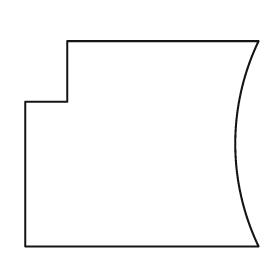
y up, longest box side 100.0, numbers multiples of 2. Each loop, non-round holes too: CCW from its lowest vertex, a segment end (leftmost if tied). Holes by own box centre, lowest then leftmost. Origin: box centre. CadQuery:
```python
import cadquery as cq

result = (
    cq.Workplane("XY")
    .moveTo(-50.0, -44.0)
    .lineTo(50.0, -44.0)
    .threePointArc((40.0, 0.0), (50.0, 44.0))
    .lineTo(-32.0, 44.0)
    .lineTo(-32.0, 18.0)
    .lineTo(-50.0, 18.0)
    .close()
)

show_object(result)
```